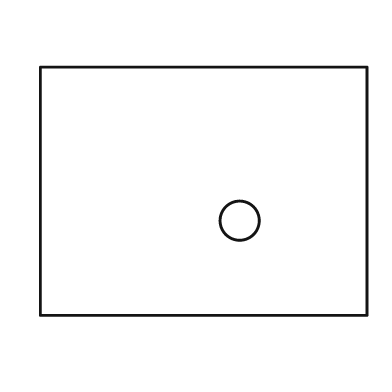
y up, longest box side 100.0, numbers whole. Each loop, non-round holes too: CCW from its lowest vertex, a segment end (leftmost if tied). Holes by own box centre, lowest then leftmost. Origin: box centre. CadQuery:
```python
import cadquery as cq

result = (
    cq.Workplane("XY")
    .moveTo(-50.0, -38.0)
    .lineTo(50.0, -38.0)
    .lineTo(50.0, 38.0)
    .lineTo(-50.0, 38.0)
    .close()
    .moveTo(11.0, -9.0)
    .circle(6.0)
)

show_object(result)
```